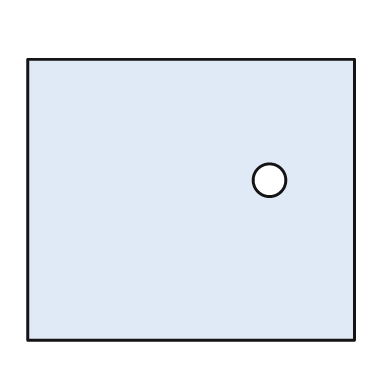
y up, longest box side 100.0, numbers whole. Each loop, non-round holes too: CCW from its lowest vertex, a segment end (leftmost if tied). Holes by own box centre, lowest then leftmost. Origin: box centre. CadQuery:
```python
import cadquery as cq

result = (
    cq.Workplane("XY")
    .moveTo(-50.0, -43.0)
    .lineTo(50.0, -43.0)
    .lineTo(50.0, 43.0)
    .lineTo(-50.0, 43.0)
    .close()
    .moveTo(24.0, 6.0)
    .circle(5.0)
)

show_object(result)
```